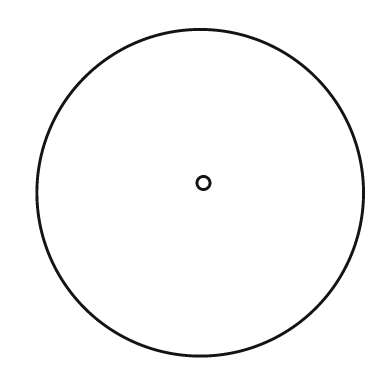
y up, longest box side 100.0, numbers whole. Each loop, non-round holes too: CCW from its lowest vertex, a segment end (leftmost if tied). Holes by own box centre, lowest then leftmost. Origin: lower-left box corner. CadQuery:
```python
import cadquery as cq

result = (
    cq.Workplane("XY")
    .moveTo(50.0, 50.0)
    .circle(50.0)
    .moveTo(51.0, 53.0)
    .circle(2.0)
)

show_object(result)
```